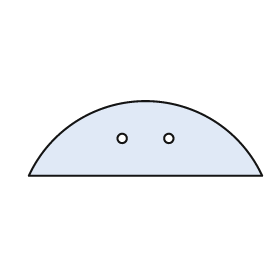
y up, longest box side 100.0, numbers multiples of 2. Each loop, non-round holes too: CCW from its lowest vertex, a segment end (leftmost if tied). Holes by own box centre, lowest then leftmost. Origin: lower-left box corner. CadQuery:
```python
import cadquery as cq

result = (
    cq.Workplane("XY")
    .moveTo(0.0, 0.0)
    .lineTo(100.0, 0.0)
    .threePointArc((50.0, 32.0), (0.0, 0.0))
    .close()
    .moveTo(40.0, 16.0)
    .circle(2.0)
    .moveTo(60.0, 16.0)
    .circle(2.0)
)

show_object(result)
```